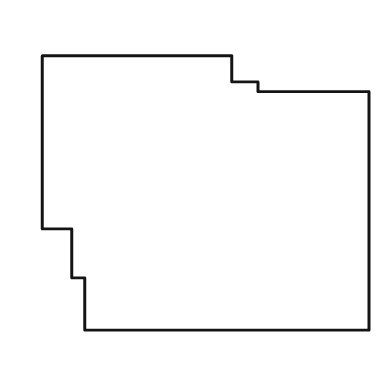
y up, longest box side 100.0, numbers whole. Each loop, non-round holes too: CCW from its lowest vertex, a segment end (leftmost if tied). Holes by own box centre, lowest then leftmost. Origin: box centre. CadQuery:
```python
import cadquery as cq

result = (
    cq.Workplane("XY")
    .moveTo(-37.0, -42.0)
    .lineTo(50.0, -42.0)
    .lineTo(50.0, 31.0)
    .lineTo(16.0, 31.0)
    .lineTo(16.0, 34.0)
    .lineTo(8.0, 34.0)
    .lineTo(8.0, 42.0)
    .lineTo(-50.0, 42.0)
    .lineTo(-50.0, -11.0)
    .lineTo(-41.0, -11.0)
    .lineTo(-41.0, -26.0)
    .lineTo(-37.0, -26.0)
    .close()
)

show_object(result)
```